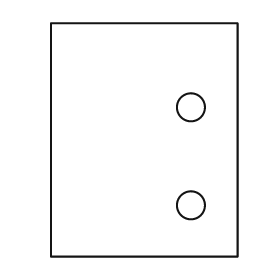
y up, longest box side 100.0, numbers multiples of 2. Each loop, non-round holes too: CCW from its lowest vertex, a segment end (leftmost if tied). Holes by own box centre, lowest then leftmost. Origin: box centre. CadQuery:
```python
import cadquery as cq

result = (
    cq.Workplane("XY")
    .moveTo(-40.0, -50.0)
    .lineTo(40.0, -50.0)
    .lineTo(40.0, 50.0)
    .lineTo(-40.0, 50.0)
    .close()
    .moveTo(20.0, -28.0)
    .circle(6.0)
    .moveTo(20.0, 14.0)
    .circle(6.0)
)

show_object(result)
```